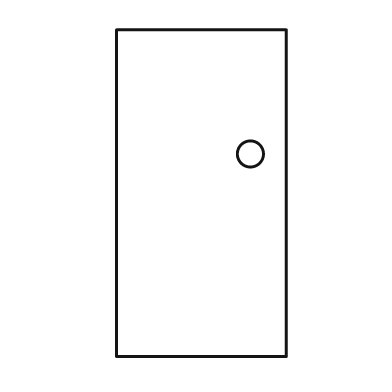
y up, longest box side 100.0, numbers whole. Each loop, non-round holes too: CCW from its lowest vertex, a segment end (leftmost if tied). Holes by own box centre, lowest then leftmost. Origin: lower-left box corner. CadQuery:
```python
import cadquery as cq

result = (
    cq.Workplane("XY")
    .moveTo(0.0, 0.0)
    .lineTo(52.0, 0.0)
    .lineTo(52.0, 100.0)
    .lineTo(0.0, 100.0)
    .close()
    .moveTo(41.0, 62.0)
    .circle(4.0)
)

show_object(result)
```